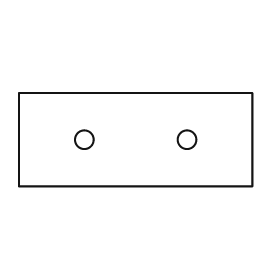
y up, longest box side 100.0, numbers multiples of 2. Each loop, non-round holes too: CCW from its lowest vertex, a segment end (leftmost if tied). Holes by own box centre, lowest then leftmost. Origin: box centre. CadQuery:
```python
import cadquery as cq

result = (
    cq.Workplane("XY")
    .moveTo(-50.0, -20.0)
    .lineTo(50.0, -20.0)
    .lineTo(50.0, 20.0)
    .lineTo(-50.0, 20.0)
    .close()
    .moveTo(-22.0, 0.0)
    .circle(4.0)
    .moveTo(22.0, 0.0)
    .circle(4.0)
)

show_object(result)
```